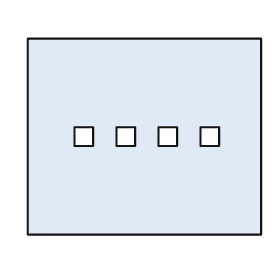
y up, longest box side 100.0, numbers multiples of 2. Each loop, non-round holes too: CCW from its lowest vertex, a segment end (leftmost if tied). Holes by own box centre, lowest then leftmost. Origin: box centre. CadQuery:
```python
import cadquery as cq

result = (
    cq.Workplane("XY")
    .moveTo(-50.0, -42.0)
    .lineTo(50.0, -42.0)
    .lineTo(50.0, 42.0)
    .lineTo(-50.0, 42.0)
    .close()
    .moveTo(-30.0, -4.0)
    .lineTo(-22.0, -4.0)
    .lineTo(-22.0, 4.0)
    .lineTo(-30.0, 4.0)
    .close()
    .moveTo(-12.0, -4.0)
    .lineTo(-4.0, -4.0)
    .lineTo(-4.0, 4.0)
    .lineTo(-12.0, 4.0)
    .close()
    .moveTo(6.0, -4.0)
    .lineTo(14.0, -4.0)
    .lineTo(14.0, 4.0)
    .lineTo(6.0, 4.0)
    .close()
    .moveTo(24.0, -4.0)
    .lineTo(32.0, -4.0)
    .lineTo(32.0, 4.0)
    .lineTo(24.0, 4.0)
    .close()
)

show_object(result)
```